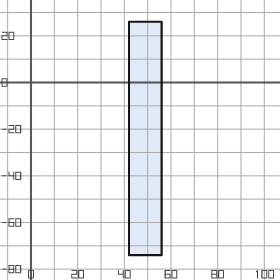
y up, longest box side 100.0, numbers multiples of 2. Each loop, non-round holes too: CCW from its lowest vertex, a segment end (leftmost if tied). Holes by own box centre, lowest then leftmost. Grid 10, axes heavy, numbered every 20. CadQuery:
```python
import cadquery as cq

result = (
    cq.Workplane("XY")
    .moveTo(42.0, -74.0)
    .lineTo(56.0, -74.0)
    .lineTo(56.0, 26.0)
    .lineTo(42.0, 26.0)
    .close()
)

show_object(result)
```